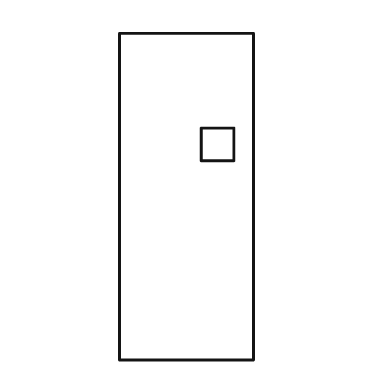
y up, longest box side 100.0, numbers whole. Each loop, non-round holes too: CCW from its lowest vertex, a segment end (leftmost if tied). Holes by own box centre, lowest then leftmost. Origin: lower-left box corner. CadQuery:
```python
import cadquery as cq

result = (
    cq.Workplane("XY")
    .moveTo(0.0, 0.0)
    .lineTo(41.0, 0.0)
    .lineTo(41.0, 100.0)
    .lineTo(0.0, 100.0)
    .close()
    .moveTo(25.0, 61.0)
    .lineTo(35.0, 61.0)
    .lineTo(35.0, 71.0)
    .lineTo(25.0, 71.0)
    .close()
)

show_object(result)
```